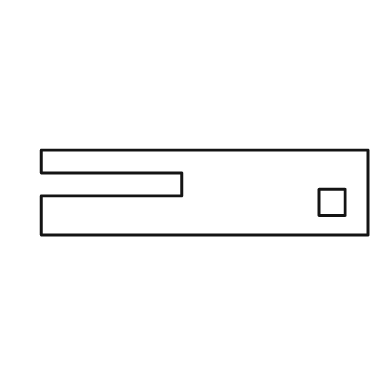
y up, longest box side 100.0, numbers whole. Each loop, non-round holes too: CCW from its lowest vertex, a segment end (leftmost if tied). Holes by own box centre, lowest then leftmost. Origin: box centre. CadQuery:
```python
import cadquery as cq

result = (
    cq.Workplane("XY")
    .moveTo(-50.0, -13.0)
    .lineTo(50.0, -13.0)
    .lineTo(50.0, 13.0)
    .lineTo(-50.0, 13.0)
    .lineTo(-50.0, 6.0)
    .lineTo(-7.0, 6.0)
    .lineTo(-7.0, -1.0)
    .lineTo(-50.0, -1.0)
    .close()
    .moveTo(35.0, -7.0)
    .lineTo(43.0, -7.0)
    .lineTo(43.0, 1.0)
    .lineTo(35.0, 1.0)
    .close()
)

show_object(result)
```